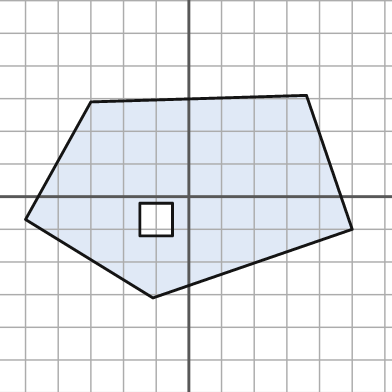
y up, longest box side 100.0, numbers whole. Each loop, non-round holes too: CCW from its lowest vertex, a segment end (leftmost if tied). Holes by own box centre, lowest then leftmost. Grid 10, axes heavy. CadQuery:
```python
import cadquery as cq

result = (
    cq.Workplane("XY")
    .moveTo(-11.0, -31.0)
    .lineTo(50.0, -10.0)
    .lineTo(36.0, 31.0)
    .lineTo(-30.0, 29.0)
    .lineTo(-50.0, -7.0)
    .close()
    .moveTo(-15.0, -12.0)
    .lineTo(-5.0, -12.0)
    .lineTo(-5.0, -2.0)
    .lineTo(-15.0, -2.0)
    .close()
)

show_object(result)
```